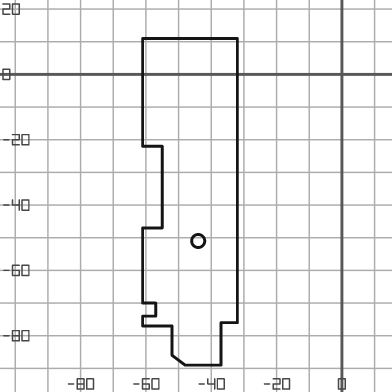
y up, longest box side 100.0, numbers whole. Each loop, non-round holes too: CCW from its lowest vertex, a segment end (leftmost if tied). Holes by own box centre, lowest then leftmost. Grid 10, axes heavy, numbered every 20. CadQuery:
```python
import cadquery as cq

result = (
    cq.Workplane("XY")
    .moveTo(-48.0, -89.0)
    .lineTo(-37.0, -89.0)
    .lineTo(-37.0, -76.0)
    .lineTo(-32.0, -76.0)
    .lineTo(-32.0, 11.0)
    .lineTo(-61.0, 11.0)
    .lineTo(-61.0, -22.0)
    .lineTo(-55.0, -22.0)
    .lineTo(-55.0, -47.0)
    .lineTo(-61.0, -47.0)
    .lineTo(-61.0, -70.0)
    .lineTo(-57.0, -70.0)
    .lineTo(-57.0, -74.0)
    .lineTo(-61.0, -74.0)
    .lineTo(-61.0, -77.0)
    .lineTo(-52.0, -77.0)
    .lineTo(-52.0, -86.0)
    .close()
    .moveTo(-44.0, -51.0)
    .circle(2.0)
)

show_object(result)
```